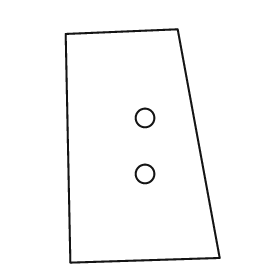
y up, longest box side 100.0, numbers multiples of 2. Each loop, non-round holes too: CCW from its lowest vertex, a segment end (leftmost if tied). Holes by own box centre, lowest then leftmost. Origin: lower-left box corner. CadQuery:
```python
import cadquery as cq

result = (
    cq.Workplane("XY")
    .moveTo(2.0, 0.0)
    .lineTo(66.0, 2.0)
    .lineTo(48.0, 100.0)
    .lineTo(0.0, 98.0)
    .close()
    .moveTo(34.0, 38.0)
    .circle(4.0)
    .moveTo(34.0, 62.0)
    .circle(4.0)
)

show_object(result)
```